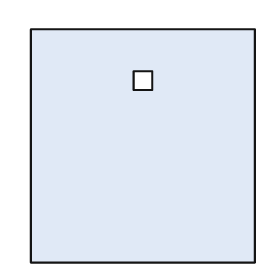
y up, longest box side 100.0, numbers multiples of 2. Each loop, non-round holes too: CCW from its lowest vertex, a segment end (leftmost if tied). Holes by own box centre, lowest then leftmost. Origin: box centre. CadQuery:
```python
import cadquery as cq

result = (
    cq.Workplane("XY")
    .moveTo(-48.0, -50.0)
    .lineTo(48.0, -50.0)
    .lineTo(48.0, 50.0)
    .lineTo(-48.0, 50.0)
    .close()
    .moveTo(-4.0, 24.0)
    .lineTo(4.0, 24.0)
    .lineTo(4.0, 32.0)
    .lineTo(-4.0, 32.0)
    .close()
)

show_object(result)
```